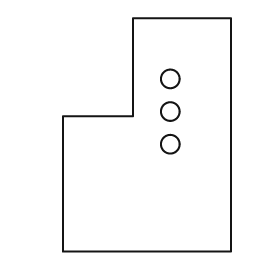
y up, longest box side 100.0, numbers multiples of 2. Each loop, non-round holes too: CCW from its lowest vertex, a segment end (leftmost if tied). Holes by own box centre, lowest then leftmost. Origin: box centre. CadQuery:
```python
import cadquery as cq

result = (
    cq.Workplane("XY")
    .moveTo(-36.0, -50.0)
    .lineTo(36.0, -50.0)
    .lineTo(36.0, 50.0)
    .lineTo(-6.0, 50.0)
    .lineTo(-6.0, 8.0)
    .lineTo(-36.0, 8.0)
    .close()
    .moveTo(10.0, -4.0)
    .circle(4.0)
    .moveTo(10.0, 10.0)
    .circle(4.0)
    .moveTo(10.0, 24.0)
    .circle(4.0)
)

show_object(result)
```